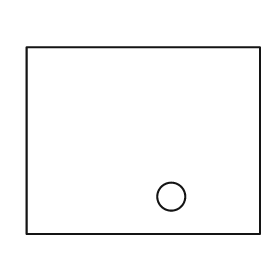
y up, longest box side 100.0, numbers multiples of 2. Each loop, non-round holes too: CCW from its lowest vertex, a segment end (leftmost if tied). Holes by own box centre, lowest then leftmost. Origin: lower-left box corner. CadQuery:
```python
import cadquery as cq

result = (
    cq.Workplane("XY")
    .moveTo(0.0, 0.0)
    .lineTo(100.0, 0.0)
    .lineTo(100.0, 80.0)
    .lineTo(0.0, 80.0)
    .close()
    .moveTo(62.0, 16.0)
    .circle(6.0)
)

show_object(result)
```